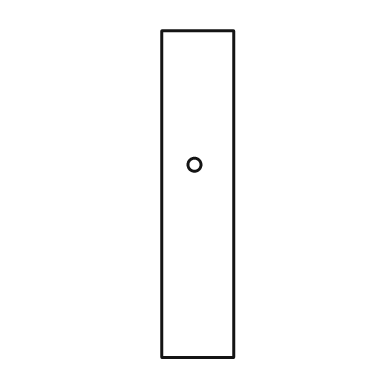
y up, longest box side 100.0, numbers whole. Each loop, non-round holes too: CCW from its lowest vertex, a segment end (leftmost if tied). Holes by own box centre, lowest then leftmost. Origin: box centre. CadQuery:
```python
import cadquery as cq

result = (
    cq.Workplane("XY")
    .moveTo(-11.0, -50.0)
    .lineTo(11.0, -50.0)
    .lineTo(11.0, 50.0)
    .lineTo(-11.0, 50.0)
    .close()
    .moveTo(-1.0, 9.0)
    .circle(2.0)
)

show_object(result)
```